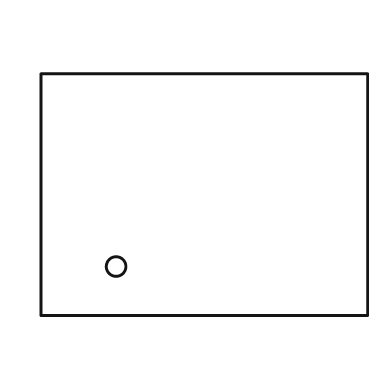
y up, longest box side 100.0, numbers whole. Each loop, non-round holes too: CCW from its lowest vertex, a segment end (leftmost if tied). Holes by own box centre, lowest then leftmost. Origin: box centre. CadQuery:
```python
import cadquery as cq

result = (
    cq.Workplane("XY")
    .moveTo(-50.0, -37.0)
    .lineTo(50.0, -37.0)
    .lineTo(50.0, 37.0)
    .lineTo(-50.0, 37.0)
    .close()
    .moveTo(-27.0, -22.0)
    .circle(3.0)
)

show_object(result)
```